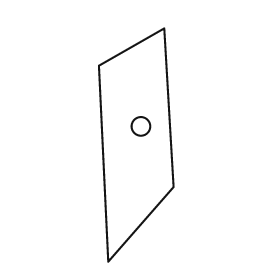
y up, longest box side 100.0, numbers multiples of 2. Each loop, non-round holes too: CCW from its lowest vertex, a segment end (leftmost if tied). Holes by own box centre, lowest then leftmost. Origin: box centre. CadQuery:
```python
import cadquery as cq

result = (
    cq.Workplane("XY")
    .moveTo(-12.0, -50.0)
    .lineTo(16.0, -18.0)
    .lineTo(12.0, 50.0)
    .lineTo(-16.0, 34.0)
    .close()
    .moveTo(2.0, 8.0)
    .circle(4.0)
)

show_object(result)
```